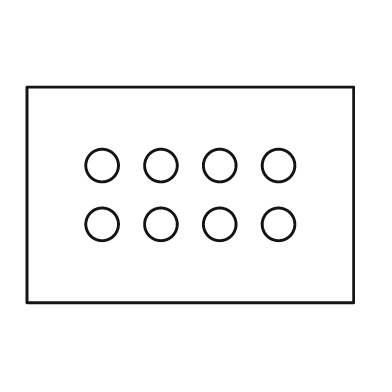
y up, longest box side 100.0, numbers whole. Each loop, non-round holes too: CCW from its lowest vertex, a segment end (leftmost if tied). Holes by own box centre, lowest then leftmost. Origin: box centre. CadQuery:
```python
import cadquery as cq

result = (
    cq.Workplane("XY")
    .moveTo(-50.0, -33.0)
    .lineTo(50.0, -33.0)
    .lineTo(50.0, 33.0)
    .lineTo(-50.0, 33.0)
    .close()
    .moveTo(-27.0, -9.0)
    .circle(5.0)
    .moveTo(-9.0, -9.0)
    .circle(5.0)
    .moveTo(9.0, -9.0)
    .circle(5.0)
    .moveTo(27.0, -9.0)
    .circle(5.0)
    .moveTo(-27.0, 9.0)
    .circle(5.0)
    .moveTo(-9.0, 9.0)
    .circle(5.0)
    .moveTo(9.0, 9.0)
    .circle(5.0)
    .moveTo(27.0, 9.0)
    .circle(5.0)
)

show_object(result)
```